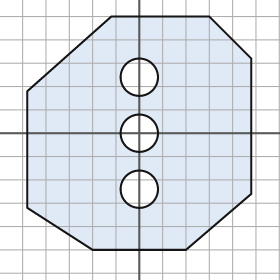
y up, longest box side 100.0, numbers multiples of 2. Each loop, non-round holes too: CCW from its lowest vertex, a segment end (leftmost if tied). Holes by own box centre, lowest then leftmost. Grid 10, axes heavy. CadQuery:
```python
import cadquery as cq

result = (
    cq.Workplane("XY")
    .moveTo(-20.0, -50.0)
    .lineTo(20.0, -50.0)
    .lineTo(48.0, -26.0)
    .lineTo(48.0, 32.0)
    .lineTo(30.0, 50.0)
    .lineTo(-12.0, 50.0)
    .lineTo(-48.0, 18.0)
    .lineTo(-48.0, -32.0)
    .close()
    .moveTo(0.0, -24.0)
    .circle(8.0)
    .moveTo(0.0, 0.0)
    .circle(8.0)
    .moveTo(0.0, 24.0)
    .circle(8.0)
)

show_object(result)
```